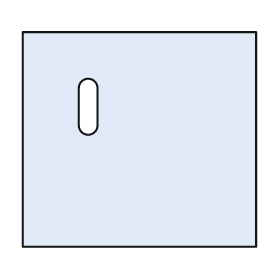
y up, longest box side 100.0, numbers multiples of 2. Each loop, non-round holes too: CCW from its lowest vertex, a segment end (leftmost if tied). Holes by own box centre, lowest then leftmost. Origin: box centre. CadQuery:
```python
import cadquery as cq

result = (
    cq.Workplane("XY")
    .moveTo(-50.0, -46.0)
    .lineTo(50.0, -46.0)
    .lineTo(50.0, 46.0)
    .lineTo(-50.0, 46.0)
    .close()
    .moveTo(-26.0, 6.0)
    .threePointArc((-22.0, 2.0), (-18.0, 6.0))
    .lineTo(-18.0, 22.0)
    .threePointArc((-22.0, 26.0), (-26.0, 22.0))
    .close()
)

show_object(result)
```